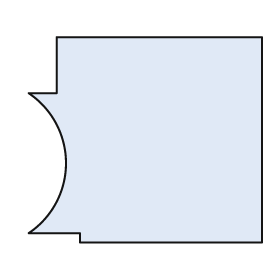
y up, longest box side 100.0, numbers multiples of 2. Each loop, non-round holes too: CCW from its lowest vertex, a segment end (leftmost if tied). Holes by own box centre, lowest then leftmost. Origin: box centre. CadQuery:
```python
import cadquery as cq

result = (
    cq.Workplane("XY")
    .moveTo(-28.0, -44.0)
    .lineTo(50.0, -44.0)
    .lineTo(50.0, 44.0)
    .lineTo(-38.0, 44.0)
    .lineTo(-38.0, 20.0)
    .lineTo(-50.0, 20.0)
    .threePointArc((-34.0, -10.0), (-50.0, -40.0))
    .lineTo(-28.0, -40.0)
    .close()
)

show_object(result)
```